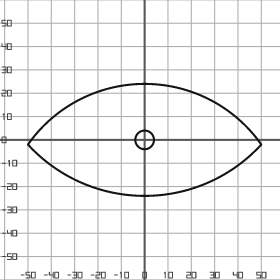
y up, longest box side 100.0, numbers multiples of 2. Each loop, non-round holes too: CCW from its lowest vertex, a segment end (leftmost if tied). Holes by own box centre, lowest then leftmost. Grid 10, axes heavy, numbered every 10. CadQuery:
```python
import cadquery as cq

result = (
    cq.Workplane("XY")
    .moveTo(-50.0, -2.0)
    .threePointArc((0.0, -24.0), (50.0, -2.0))
    .threePointArc((0.0, 24.0), (-50.0, -2.0))
    .close()
    .moveTo(0.0, 0.0)
    .circle(4.0)
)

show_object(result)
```